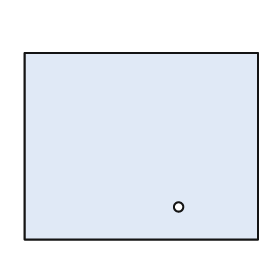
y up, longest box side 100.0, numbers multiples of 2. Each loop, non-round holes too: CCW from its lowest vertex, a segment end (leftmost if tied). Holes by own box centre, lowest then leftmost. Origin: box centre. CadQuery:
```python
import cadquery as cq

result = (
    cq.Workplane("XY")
    .moveTo(-50.0, -40.0)
    .lineTo(50.0, -40.0)
    .lineTo(50.0, 40.0)
    .lineTo(-50.0, 40.0)
    .close()
    .moveTo(16.0, -26.0)
    .circle(2.0)
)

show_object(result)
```